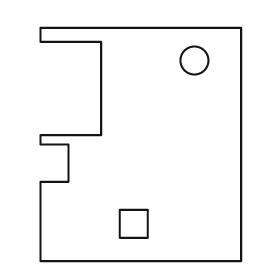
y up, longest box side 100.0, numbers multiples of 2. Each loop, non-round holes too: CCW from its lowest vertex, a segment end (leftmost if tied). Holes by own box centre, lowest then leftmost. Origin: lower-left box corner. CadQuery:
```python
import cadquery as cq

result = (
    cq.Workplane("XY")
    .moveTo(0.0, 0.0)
    .lineTo(86.0, 0.0)
    .lineTo(86.0, 100.0)
    .lineTo(0.0, 100.0)
    .lineTo(0.0, 94.0)
    .lineTo(26.0, 94.0)
    .lineTo(26.0, 54.0)
    .lineTo(0.0, 54.0)
    .lineTo(0.0, 50.0)
    .lineTo(12.0, 50.0)
    .lineTo(12.0, 34.0)
    .lineTo(0.0, 34.0)
    .close()
    .moveTo(34.0, 10.0)
    .lineTo(46.0, 10.0)
    .lineTo(46.0, 22.0)
    .lineTo(34.0, 22.0)
    .close()
    .moveTo(66.0, 86.0)
    .circle(6.0)
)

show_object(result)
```